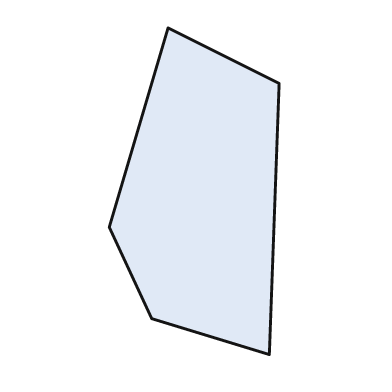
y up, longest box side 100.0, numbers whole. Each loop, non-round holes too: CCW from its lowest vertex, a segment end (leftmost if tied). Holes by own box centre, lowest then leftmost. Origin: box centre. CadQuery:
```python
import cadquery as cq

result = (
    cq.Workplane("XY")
    .moveTo(23.0, -50.0)
    .lineTo(26.0, 33.0)
    .lineTo(-8.0, 50.0)
    .lineTo(-26.0, -11.0)
    .lineTo(-13.0, -39.0)
    .close()
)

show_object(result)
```